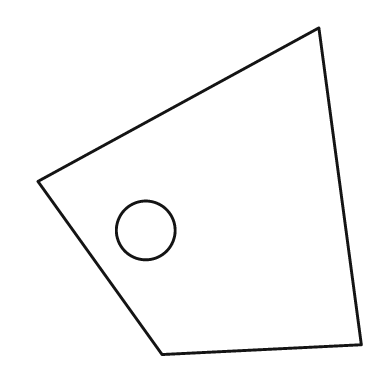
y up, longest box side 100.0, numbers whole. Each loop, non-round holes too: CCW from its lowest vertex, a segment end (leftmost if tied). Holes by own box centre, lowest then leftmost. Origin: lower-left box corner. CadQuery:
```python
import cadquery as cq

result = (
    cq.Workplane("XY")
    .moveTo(38.0, 0.0)
    .lineTo(99.0, 3.0)
    .lineTo(86.0, 100.0)
    .lineTo(0.0, 53.0)
    .close()
    .moveTo(33.0, 38.0)
    .circle(9.0)
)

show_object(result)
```